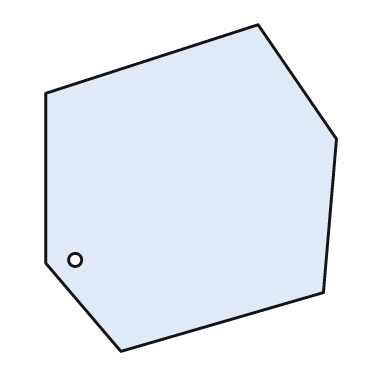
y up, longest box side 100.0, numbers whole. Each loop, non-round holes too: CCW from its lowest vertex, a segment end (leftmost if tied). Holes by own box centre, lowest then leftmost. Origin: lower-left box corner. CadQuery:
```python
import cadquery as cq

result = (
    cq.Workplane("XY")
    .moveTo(23.0, 0.0)
    .lineTo(85.0, 18.0)
    .lineTo(89.0, 65.0)
    .lineTo(65.0, 100.0)
    .lineTo(0.0, 79.0)
    .lineTo(0.0, 27.0)
    .close()
    .moveTo(9.0, 28.0)
    .circle(2.0)
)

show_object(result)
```